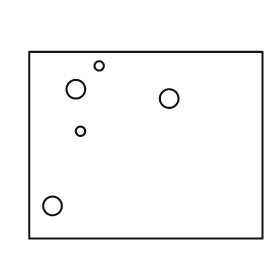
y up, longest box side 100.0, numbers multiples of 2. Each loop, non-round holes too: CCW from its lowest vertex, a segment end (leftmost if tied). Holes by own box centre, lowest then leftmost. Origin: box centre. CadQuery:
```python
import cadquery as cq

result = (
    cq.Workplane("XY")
    .moveTo(-50.0, -40.0)
    .lineTo(50.0, -40.0)
    .lineTo(50.0, 40.0)
    .lineTo(-50.0, 40.0)
    .close()
    .moveTo(-40.0, -26.0)
    .circle(4.0)
    .moveTo(-28.0, 6.0)
    .circle(2.0)
    .moveTo(10.0, 20.0)
    .circle(4.0)
    .moveTo(-30.0, 24.0)
    .circle(4.0)
    .moveTo(-20.0, 34.0)
    .circle(2.0)
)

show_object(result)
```